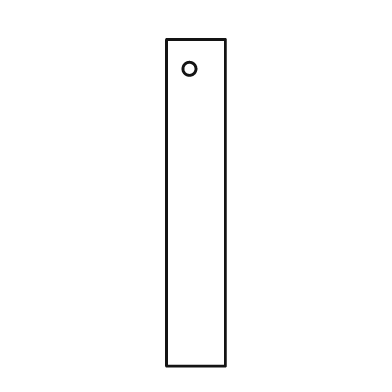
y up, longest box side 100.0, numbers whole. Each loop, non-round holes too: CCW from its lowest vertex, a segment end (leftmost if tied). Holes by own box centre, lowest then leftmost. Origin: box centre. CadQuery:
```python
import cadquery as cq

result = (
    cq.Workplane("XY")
    .moveTo(-9.0, -50.0)
    .lineTo(9.0, -50.0)
    .lineTo(9.0, 50.0)
    .lineTo(-9.0, 50.0)
    .close()
    .moveTo(-2.0, 41.0)
    .circle(2.0)
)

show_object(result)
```